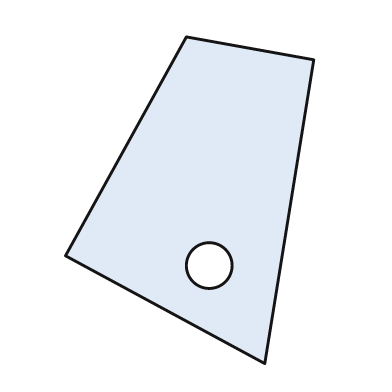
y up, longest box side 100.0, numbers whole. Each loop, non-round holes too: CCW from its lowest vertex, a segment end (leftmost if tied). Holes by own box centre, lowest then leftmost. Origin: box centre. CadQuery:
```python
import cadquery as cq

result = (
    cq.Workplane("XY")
    .moveTo(23.0, -50.0)
    .lineTo(38.0, 43.0)
    .lineTo(-1.0, 50.0)
    .lineTo(-38.0, -17.0)
    .close()
    .moveTo(6.0, -20.0)
    .circle(7.0)
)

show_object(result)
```